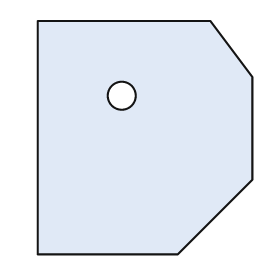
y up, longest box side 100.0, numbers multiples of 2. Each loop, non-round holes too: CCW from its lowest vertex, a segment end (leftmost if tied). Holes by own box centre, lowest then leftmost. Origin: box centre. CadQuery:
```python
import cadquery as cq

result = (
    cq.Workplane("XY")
    .moveTo(-46.0, -50.0)
    .lineTo(14.0, -50.0)
    .lineTo(46.0, -18.0)
    .lineTo(46.0, 26.0)
    .lineTo(28.0, 50.0)
    .lineTo(-46.0, 50.0)
    .close()
    .moveTo(-10.0, 18.0)
    .circle(6.0)
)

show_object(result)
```